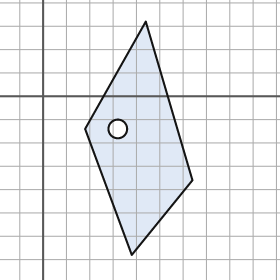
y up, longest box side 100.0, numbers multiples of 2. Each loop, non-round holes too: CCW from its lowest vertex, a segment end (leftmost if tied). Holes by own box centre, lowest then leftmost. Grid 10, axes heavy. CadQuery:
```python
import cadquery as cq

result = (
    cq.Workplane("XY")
    .moveTo(38.0, -68.0)
    .lineTo(64.0, -36.0)
    .lineTo(44.0, 32.0)
    .lineTo(18.0, -14.0)
    .close()
    .moveTo(32.0, -14.0)
    .circle(4.0)
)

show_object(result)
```